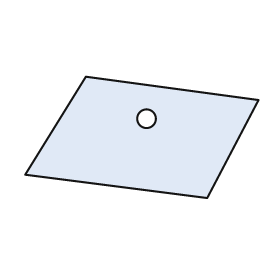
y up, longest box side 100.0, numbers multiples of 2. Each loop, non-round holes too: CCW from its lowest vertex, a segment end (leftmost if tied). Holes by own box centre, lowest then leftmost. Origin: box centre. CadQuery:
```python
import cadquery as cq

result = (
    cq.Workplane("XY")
    .moveTo(28.0, -26.0)
    .lineTo(50.0, 16.0)
    .lineTo(-24.0, 26.0)
    .lineTo(-50.0, -16.0)
    .close()
    .moveTo(2.0, 8.0)
    .circle(4.0)
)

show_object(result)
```